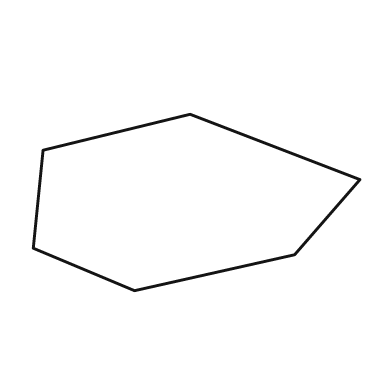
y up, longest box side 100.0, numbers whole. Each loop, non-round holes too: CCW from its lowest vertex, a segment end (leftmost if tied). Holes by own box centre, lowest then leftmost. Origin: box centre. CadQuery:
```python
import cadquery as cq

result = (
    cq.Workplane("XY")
    .moveTo(-19.0, -27.0)
    .lineTo(30.0, -16.0)
    .lineTo(50.0, 7.0)
    .lineTo(-2.0, 27.0)
    .lineTo(-47.0, 16.0)
    .lineTo(-50.0, -14.0)
    .close()
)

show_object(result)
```